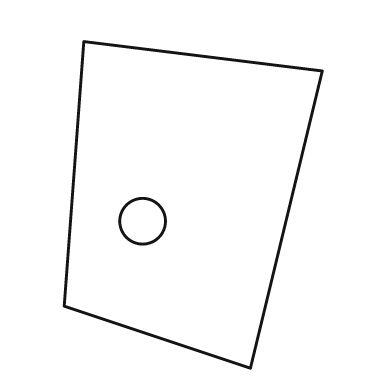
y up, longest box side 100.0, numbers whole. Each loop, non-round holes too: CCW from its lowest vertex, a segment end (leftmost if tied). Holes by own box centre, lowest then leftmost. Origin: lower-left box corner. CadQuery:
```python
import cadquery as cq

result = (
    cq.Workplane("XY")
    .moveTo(57.0, 0.0)
    .lineTo(79.0, 91.0)
    .lineTo(6.0, 100.0)
    .lineTo(0.0, 19.0)
    .close()
    .moveTo(24.0, 45.0)
    .circle(7.0)
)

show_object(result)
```